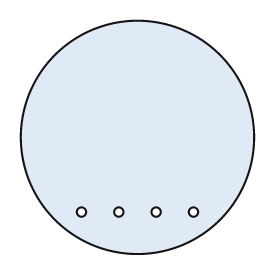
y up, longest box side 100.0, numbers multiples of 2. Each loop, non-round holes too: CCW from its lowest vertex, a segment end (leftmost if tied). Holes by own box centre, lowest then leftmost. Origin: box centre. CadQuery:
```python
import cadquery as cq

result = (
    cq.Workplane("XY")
    .moveTo(0.0, 0.0)
    .circle(50.0)
    .moveTo(-24.0, -32.0)
    .circle(2.0)
    .moveTo(-8.0, -32.0)
    .circle(2.0)
    .moveTo(8.0, -32.0)
    .circle(2.0)
    .moveTo(24.0, -32.0)
    .circle(2.0)
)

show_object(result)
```